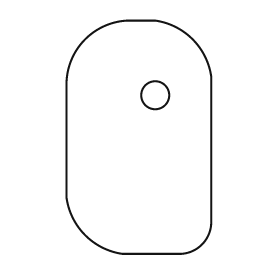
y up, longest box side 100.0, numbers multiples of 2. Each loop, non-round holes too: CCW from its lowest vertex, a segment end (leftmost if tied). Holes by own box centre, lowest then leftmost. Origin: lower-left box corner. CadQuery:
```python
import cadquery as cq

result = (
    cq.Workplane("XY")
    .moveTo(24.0, 0.0)
    .lineTo(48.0, 0.0)
    .threePointArc((58.0, 4.0), (62.0, 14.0))
    .lineTo(62.0, 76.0)
    .threePointArc((54.0, 92.0), (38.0, 100.0))
    .lineTo(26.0, 100.0)
    .threePointArc((8.0, 92.0), (0.0, 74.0))
    .lineTo(0.0, 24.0)
    .threePointArc((8.0, 8.0), (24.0, 0.0))
    .close()
    .moveTo(38.0, 68.0)
    .circle(6.0)
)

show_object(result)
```